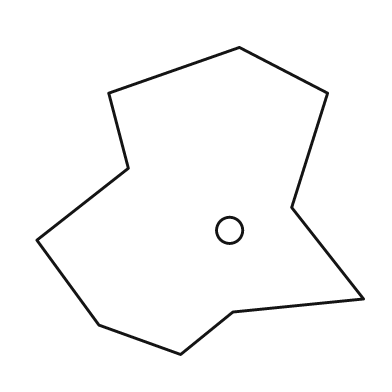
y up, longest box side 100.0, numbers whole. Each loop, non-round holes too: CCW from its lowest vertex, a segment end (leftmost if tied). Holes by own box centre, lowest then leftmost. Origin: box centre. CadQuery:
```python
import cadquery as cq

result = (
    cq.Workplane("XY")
    .moveTo(-6.0, -47.0)
    .lineTo(10.0, -34.0)
    .lineTo(50.0, -30.0)
    .lineTo(28.0, -2.0)
    .lineTo(39.0, 33.0)
    .lineTo(12.0, 47.0)
    .lineTo(-28.0, 33.0)
    .lineTo(-22.0, 10.0)
    .lineTo(-50.0, -12.0)
    .lineTo(-31.0, -38.0)
    .close()
    .moveTo(9.0, -9.0)
    .circle(4.0)
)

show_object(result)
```